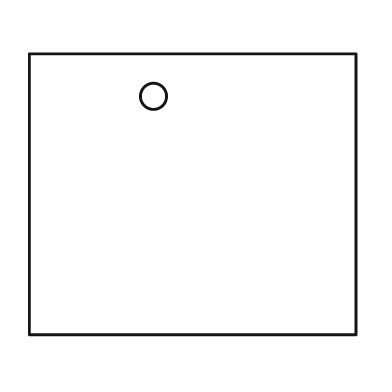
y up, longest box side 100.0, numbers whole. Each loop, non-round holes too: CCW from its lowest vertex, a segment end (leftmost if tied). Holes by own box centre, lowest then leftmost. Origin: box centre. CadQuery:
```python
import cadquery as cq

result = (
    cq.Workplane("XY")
    .moveTo(-50.0, -43.0)
    .lineTo(50.0, -43.0)
    .lineTo(50.0, 43.0)
    .lineTo(-50.0, 43.0)
    .close()
    .moveTo(-12.0, 30.0)
    .circle(4.0)
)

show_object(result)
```